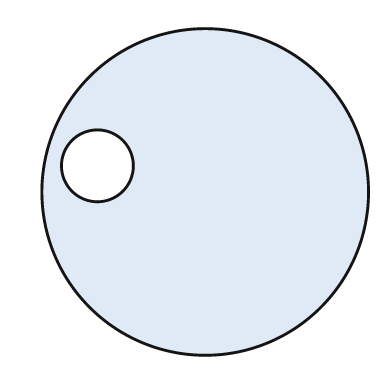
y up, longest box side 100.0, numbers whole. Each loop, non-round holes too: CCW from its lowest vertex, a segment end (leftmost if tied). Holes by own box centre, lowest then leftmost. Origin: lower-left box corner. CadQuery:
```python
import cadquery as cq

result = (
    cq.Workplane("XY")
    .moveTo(50.0, 50.0)
    .circle(50.0)
    .moveTo(17.0, 58.0)
    .circle(11.0)
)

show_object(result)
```